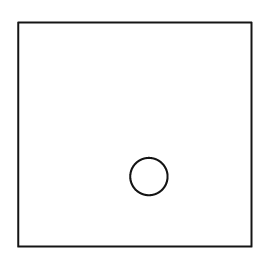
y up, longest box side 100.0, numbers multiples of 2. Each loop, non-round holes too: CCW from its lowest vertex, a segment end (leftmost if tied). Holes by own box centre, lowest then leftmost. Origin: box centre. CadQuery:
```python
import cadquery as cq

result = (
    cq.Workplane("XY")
    .moveTo(-50.0, -48.0)
    .lineTo(50.0, -48.0)
    .lineTo(50.0, 48.0)
    .lineTo(-50.0, 48.0)
    .close()
    .moveTo(6.0, -18.0)
    .circle(8.0)
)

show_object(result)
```